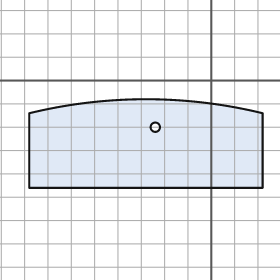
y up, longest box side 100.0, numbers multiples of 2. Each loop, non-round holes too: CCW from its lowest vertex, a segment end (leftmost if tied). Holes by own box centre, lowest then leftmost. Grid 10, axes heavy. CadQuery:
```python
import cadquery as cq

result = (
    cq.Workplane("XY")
    .moveTo(-78.0, -46.0)
    .lineTo(22.0, -46.0)
    .lineTo(22.0, -14.0)
    .threePointArc((-28.0, -8.0), (-78.0, -14.0))
    .close()
    .moveTo(-24.0, -20.0)
    .circle(2.0)
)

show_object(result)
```